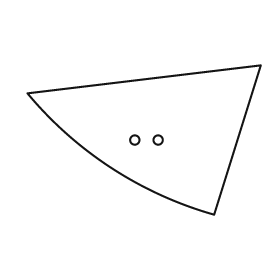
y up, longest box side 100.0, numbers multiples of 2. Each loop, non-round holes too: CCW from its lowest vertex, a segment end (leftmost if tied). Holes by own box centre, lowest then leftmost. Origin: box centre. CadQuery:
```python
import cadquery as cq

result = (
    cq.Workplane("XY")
    .moveTo(30.0, -32.0)
    .lineTo(50.0, 32.0)
    .lineTo(-50.0, 20.0)
    .threePointArc((-14.0, -12.0), (30.0, -32.0))
    .close()
    .moveTo(-4.0, 0.0)
    .circle(2.0)
    .moveTo(6.0, 0.0)
    .circle(2.0)
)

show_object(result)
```